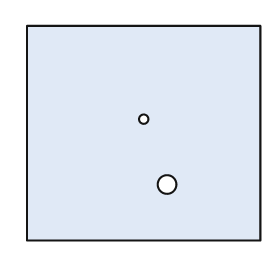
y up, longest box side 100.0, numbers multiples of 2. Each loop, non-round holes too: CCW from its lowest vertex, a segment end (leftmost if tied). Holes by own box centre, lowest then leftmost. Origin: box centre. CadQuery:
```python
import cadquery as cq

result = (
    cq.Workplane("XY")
    .moveTo(-50.0, -46.0)
    .lineTo(50.0, -46.0)
    .lineTo(50.0, 46.0)
    .lineTo(-50.0, 46.0)
    .close()
    .moveTo(10.0, -22.0)
    .circle(4.0)
    .moveTo(0.0, 6.0)
    .circle(2.0)
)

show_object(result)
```